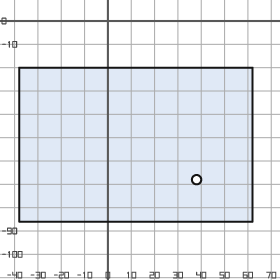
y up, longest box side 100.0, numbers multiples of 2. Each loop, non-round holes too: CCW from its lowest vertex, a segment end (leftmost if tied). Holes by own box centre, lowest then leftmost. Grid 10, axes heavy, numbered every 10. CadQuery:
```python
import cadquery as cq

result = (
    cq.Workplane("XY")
    .moveTo(-38.0, -86.0)
    .lineTo(62.0, -86.0)
    .lineTo(62.0, -20.0)
    .lineTo(-38.0, -20.0)
    .close()
    .moveTo(38.0, -68.0)
    .circle(2.0)
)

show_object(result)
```